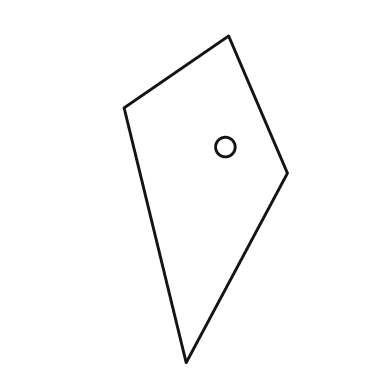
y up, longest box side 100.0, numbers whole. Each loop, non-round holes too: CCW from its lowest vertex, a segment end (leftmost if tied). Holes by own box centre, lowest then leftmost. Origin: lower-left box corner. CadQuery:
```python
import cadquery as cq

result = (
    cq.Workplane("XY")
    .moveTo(19.0, 0.0)
    .lineTo(50.0, 58.0)
    .lineTo(32.0, 100.0)
    .lineTo(0.0, 78.0)
    .close()
    .moveTo(31.0, 66.0)
    .circle(3.0)
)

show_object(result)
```